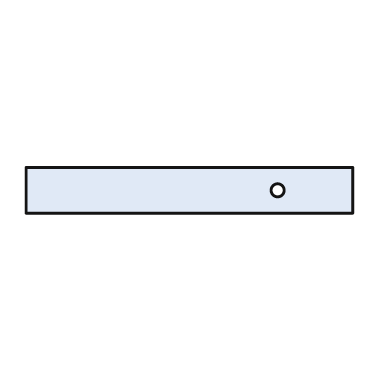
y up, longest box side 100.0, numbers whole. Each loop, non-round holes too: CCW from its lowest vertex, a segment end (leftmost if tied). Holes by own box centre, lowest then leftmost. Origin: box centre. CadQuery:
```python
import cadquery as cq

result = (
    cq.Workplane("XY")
    .moveTo(-50.0, -7.0)
    .lineTo(50.0, -7.0)
    .lineTo(50.0, 7.0)
    .lineTo(-50.0, 7.0)
    .close()
    .moveTo(27.0, 0.0)
    .circle(2.0)
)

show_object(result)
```